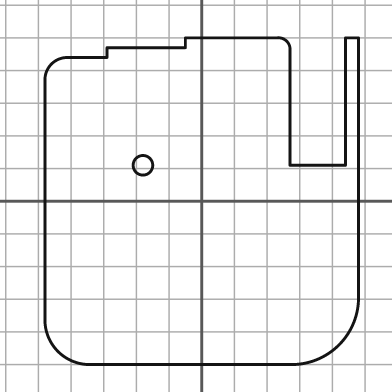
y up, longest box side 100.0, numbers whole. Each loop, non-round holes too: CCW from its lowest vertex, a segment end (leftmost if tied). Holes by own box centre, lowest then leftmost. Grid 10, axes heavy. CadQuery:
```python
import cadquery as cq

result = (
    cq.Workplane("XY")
    .moveTo(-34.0, -50.0)
    .lineTo(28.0, -50.0)
    .threePointArc((42.0, -44.0), (48.0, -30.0))
    .lineTo(48.0, 50.0)
    .lineTo(44.0, 50.0)
    .lineTo(44.0, 11.0)
    .lineTo(27.0, 11.0)
    .lineTo(27.0, 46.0)
    .threePointArc((26.0, 49.0), (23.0, 50.0))
    .lineTo(-5.0, 50.0)
    .lineTo(-5.0, 47.0)
    .lineTo(-29.0, 47.0)
    .lineTo(-29.0, 44.0)
    .lineTo(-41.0, 44.0)
    .threePointArc((-46.0, 42.0), (-48.0, 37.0))
    .lineTo(-48.0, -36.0)
    .threePointArc((-44.0, -46.0), (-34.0, -50.0))
    .close()
    .moveTo(-18.0, 11.0)
    .circle(3.0)
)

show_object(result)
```